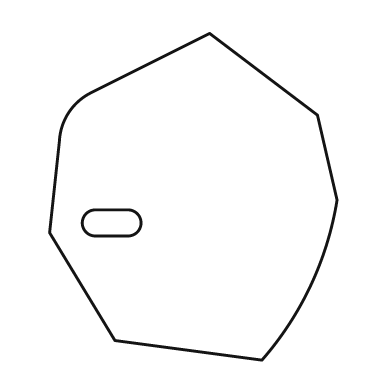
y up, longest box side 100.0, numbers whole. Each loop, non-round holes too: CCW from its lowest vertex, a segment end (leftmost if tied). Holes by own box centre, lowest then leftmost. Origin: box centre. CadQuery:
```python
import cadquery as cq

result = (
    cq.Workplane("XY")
    .moveTo(21.0, -50.0)
    .threePointArc((36.0, -27.0), (44.0, -1.0))
    .lineTo(38.0, 25.0)
    .lineTo(5.0, 50.0)
    .lineTo(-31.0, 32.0)
    .threePointArc((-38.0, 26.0), (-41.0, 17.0))
    .lineTo(-44.0, -11.0)
    .lineTo(-24.0, -44.0)
    .close()
    .moveTo(-30.0, -12.0)
    .lineTo(-20.0, -12.0)
    .threePointArc((-16.0, -8.0), (-20.0, -4.0))
    .lineTo(-30.0, -4.0)
    .threePointArc((-34.0, -8.0), (-30.0, -12.0))
    .close()
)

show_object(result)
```